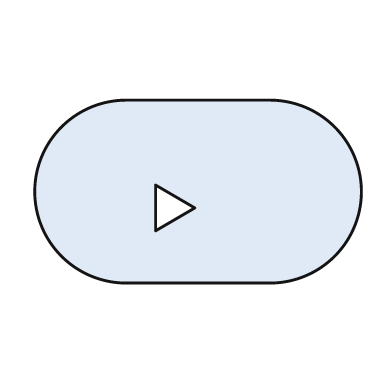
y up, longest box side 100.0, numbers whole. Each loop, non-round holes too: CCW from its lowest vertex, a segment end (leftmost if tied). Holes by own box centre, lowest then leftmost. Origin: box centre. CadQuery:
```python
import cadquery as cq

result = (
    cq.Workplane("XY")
    .moveTo(-22.0, -28.0)
    .lineTo(22.0, -28.0)
    .threePointArc((50.0, 0.0), (22.0, 28.0))
    .lineTo(-22.0, 28.0)
    .threePointArc((-50.0, 0.0), (-22.0, -28.0))
    .close()
    .moveTo(-13.0, -12.0)
    .lineTo(-1.0, -5.0)
    .lineTo(-13.0, 2.0)
    .close()
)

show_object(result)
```